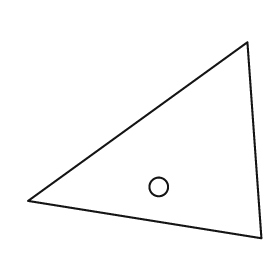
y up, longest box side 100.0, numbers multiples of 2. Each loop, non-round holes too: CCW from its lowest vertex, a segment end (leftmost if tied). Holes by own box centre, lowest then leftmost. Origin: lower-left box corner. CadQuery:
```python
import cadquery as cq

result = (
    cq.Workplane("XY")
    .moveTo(100.0, 0.0)
    .lineTo(94.0, 84.0)
    .lineTo(0.0, 16.0)
    .close()
    .moveTo(56.0, 22.0)
    .circle(4.0)
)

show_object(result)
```